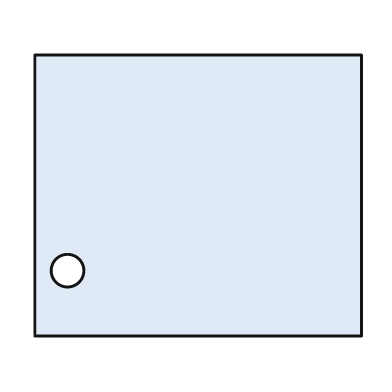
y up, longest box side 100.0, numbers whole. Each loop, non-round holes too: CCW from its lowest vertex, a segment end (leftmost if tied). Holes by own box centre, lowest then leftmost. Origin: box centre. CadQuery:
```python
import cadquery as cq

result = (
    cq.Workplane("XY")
    .moveTo(-50.0, -43.0)
    .lineTo(50.0, -43.0)
    .lineTo(50.0, 43.0)
    .lineTo(-50.0, 43.0)
    .close()
    .moveTo(-40.0, -23.0)
    .circle(5.0)
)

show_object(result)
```